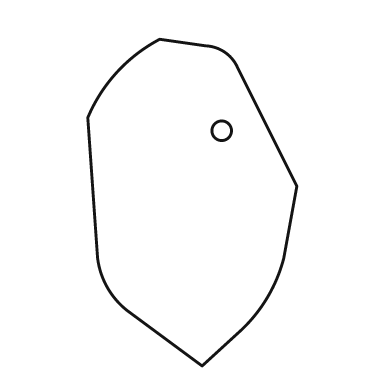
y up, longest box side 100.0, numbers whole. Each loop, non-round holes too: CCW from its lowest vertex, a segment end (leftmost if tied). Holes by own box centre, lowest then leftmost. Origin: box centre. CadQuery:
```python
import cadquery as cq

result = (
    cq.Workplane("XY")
    .moveTo(3.0, -50.0)
    .lineTo(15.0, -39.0)
    .threePointArc((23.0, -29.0), (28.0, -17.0))
    .lineTo(32.0, 5.0)
    .lineTo(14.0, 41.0)
    .threePointArc((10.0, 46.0), (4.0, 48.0))
    .lineTo(-10.0, 50.0)
    .threePointArc((-23.0, 40.0), (-32.0, 26.0))
    .lineTo(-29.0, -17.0)
    .threePointArc((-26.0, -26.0), (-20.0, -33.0))
    .close()
    .moveTo(9.0, 22.0)
    .circle(3.0)
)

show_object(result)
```